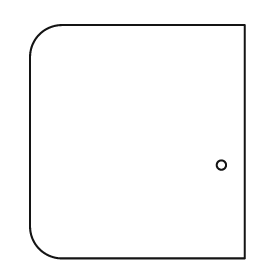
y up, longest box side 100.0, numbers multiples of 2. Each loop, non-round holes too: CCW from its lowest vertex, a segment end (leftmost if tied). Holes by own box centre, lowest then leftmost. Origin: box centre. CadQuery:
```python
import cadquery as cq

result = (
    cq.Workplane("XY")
    .moveTo(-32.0, -50.0)
    .lineTo(46.0, -50.0)
    .lineTo(46.0, 50.0)
    .lineTo(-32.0, 50.0)
    .threePointArc((-42.0, 46.0), (-46.0, 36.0))
    .lineTo(-46.0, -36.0)
    .threePointArc((-42.0, -46.0), (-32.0, -50.0))
    .close()
    .moveTo(36.0, -10.0)
    .circle(2.0)
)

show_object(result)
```